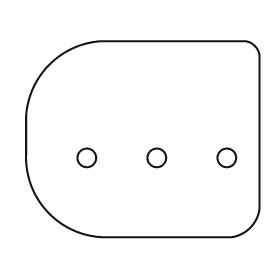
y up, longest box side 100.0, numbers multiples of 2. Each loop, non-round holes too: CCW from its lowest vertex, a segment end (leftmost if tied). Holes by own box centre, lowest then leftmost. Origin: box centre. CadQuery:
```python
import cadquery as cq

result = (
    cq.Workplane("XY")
    .moveTo(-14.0, -42.0)
    .lineTo(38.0, -42.0)
    .threePointArc((46.0, -38.0), (50.0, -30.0))
    .lineTo(50.0, 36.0)
    .threePointArc((48.0, 40.0), (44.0, 42.0))
    .lineTo(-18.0, 42.0)
    .threePointArc((-40.0, 32.0), (-50.0, 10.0))
    .lineTo(-50.0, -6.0)
    .threePointArc((-40.0, -32.0), (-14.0, -42.0))
    .close()
    .moveTo(-24.0, -8.0)
    .circle(4.0)
    .moveTo(6.0, -8.0)
    .circle(4.0)
    .moveTo(36.0, -8.0)
    .circle(4.0)
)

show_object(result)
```